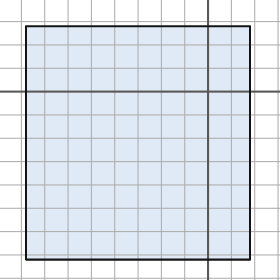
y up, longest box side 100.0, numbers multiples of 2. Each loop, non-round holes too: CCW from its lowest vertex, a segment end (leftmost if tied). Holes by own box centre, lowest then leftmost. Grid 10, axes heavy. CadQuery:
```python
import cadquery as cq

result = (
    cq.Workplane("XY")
    .moveTo(-78.0, -72.0)
    .lineTo(18.0, -72.0)
    .lineTo(18.0, 28.0)
    .lineTo(-78.0, 28.0)
    .close()
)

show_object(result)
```